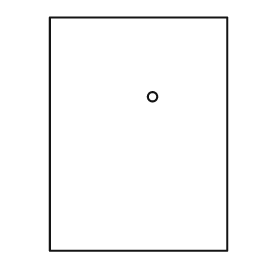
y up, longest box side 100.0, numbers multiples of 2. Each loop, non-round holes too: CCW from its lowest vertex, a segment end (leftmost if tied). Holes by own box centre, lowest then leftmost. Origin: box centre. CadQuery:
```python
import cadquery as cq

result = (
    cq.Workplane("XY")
    .moveTo(-38.0, -50.0)
    .lineTo(38.0, -50.0)
    .lineTo(38.0, 50.0)
    .lineTo(-38.0, 50.0)
    .close()
    .moveTo(6.0, 16.0)
    .circle(2.0)
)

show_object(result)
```